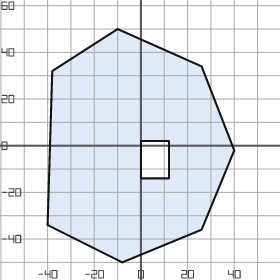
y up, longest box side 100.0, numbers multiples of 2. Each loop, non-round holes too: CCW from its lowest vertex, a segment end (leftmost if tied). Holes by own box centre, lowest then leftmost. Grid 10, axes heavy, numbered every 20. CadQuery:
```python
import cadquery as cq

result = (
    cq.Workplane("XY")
    .moveTo(-8.0, -50.0)
    .lineTo(26.0, -36.0)
    .lineTo(40.0, -2.0)
    .lineTo(26.0, 34.0)
    .lineTo(-10.0, 50.0)
    .lineTo(-38.0, 32.0)
    .lineTo(-40.0, -34.0)
    .close()
    .moveTo(0.0, -14.0)
    .lineTo(12.0, -14.0)
    .lineTo(12.0, 2.0)
    .lineTo(0.0, 2.0)
    .close()
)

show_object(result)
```